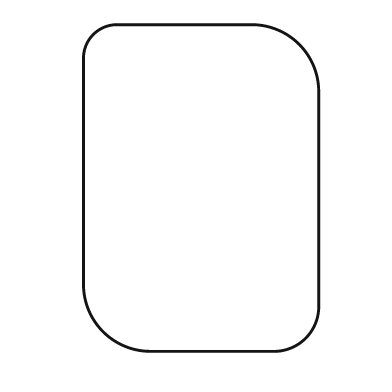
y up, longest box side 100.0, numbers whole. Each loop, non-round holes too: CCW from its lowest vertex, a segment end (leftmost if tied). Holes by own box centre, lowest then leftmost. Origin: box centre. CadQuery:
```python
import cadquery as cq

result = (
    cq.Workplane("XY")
    .moveTo(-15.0, -50.0)
    .lineTo(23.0, -50.0)
    .threePointArc((32.0, -46.0), (36.0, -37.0))
    .lineTo(36.0, 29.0)
    .threePointArc((30.0, 44.0), (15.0, 50.0))
    .lineTo(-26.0, 50.0)
    .threePointArc((-33.0, 47.0), (-36.0, 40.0))
    .lineTo(-36.0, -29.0)
    .threePointArc((-30.0, -44.0), (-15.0, -50.0))
    .close()
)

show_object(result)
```